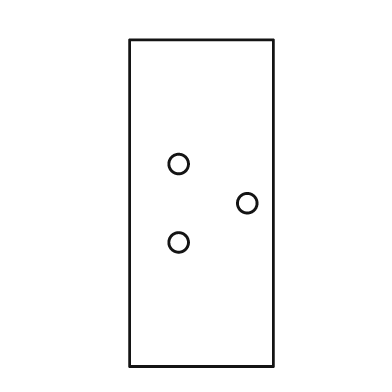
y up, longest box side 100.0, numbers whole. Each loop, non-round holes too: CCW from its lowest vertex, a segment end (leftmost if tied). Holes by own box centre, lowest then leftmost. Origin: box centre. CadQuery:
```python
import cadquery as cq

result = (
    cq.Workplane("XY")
    .moveTo(-22.0, -50.0)
    .lineTo(22.0, -50.0)
    .lineTo(22.0, 50.0)
    .lineTo(-22.0, 50.0)
    .close()
    .moveTo(-7.0, -12.0)
    .circle(3.0)
    .moveTo(14.0, 0.0)
    .circle(3.0)
    .moveTo(-7.0, 12.0)
    .circle(3.0)
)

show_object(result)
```